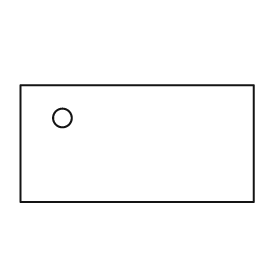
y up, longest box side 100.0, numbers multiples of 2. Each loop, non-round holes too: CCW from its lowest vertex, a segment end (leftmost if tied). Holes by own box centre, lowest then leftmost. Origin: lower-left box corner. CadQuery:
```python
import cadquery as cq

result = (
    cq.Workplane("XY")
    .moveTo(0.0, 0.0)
    .lineTo(100.0, 0.0)
    .lineTo(100.0, 50.0)
    .lineTo(0.0, 50.0)
    .close()
    .moveTo(18.0, 36.0)
    .circle(4.0)
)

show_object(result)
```